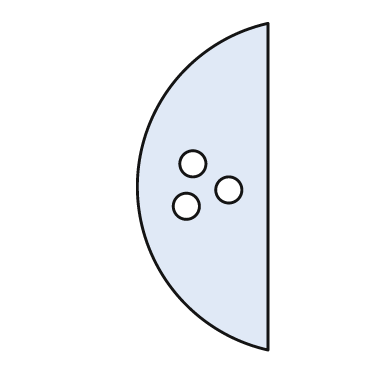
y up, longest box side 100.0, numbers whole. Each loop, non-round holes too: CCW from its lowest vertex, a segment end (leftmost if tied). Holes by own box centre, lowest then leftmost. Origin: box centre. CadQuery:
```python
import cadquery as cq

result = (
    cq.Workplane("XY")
    .moveTo(20.0, -50.0)
    .lineTo(20.0, 50.0)
    .threePointArc((-20.0, 0.0), (20.0, -50.0))
    .close()
    .moveTo(-5.0, -6.0)
    .circle(4.0)
    .moveTo(8.0, -1.0)
    .circle(4.0)
    .moveTo(-3.0, 7.0)
    .circle(4.0)
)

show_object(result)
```